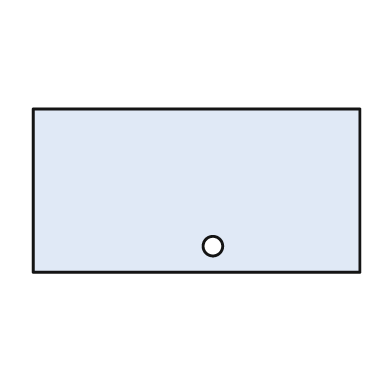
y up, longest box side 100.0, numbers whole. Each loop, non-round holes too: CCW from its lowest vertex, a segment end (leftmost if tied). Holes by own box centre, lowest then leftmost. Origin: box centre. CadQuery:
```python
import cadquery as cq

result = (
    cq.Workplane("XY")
    .moveTo(-50.0, -25.0)
    .lineTo(50.0, -25.0)
    .lineTo(50.0, 25.0)
    .lineTo(-50.0, 25.0)
    .close()
    .moveTo(5.0, -17.0)
    .circle(3.0)
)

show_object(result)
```